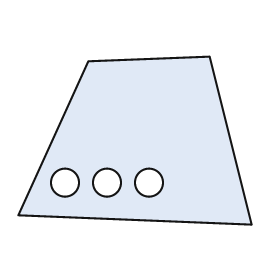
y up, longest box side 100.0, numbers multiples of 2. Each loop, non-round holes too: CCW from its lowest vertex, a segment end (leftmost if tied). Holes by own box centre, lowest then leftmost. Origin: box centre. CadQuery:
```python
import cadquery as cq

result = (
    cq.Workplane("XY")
    .moveTo(50.0, -36.0)
    .lineTo(32.0, 36.0)
    .lineTo(-20.0, 34.0)
    .lineTo(-50.0, -32.0)
    .close()
    .moveTo(-30.0, -18.0)
    .circle(6.0)
    .moveTo(-12.0, -18.0)
    .circle(6.0)
    .moveTo(6.0, -18.0)
    .circle(6.0)
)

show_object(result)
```